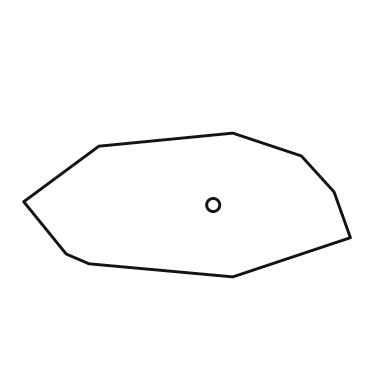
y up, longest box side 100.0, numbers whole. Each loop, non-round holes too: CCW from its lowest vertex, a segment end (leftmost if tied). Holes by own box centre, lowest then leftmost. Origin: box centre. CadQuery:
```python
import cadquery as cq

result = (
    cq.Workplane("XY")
    .moveTo(14.0, -22.0)
    .lineTo(50.0, -10.0)
    .lineTo(45.0, 4.0)
    .lineTo(35.0, 15.0)
    .lineTo(14.0, 22.0)
    .lineTo(-27.0, 18.0)
    .lineTo(-50.0, 1.0)
    .lineTo(-37.0, -15.0)
    .lineTo(-30.0, -18.0)
    .close()
    .moveTo(8.0, 0.0)
    .circle(2.0)
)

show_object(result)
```